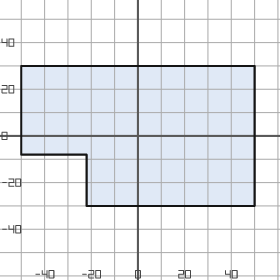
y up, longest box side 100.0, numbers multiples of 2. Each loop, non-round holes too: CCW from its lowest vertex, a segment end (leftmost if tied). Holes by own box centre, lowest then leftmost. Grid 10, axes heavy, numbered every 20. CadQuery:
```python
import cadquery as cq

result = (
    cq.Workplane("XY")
    .moveTo(-22.0, -30.0)
    .lineTo(50.0, -30.0)
    .lineTo(50.0, 30.0)
    .lineTo(-50.0, 30.0)
    .lineTo(-50.0, -8.0)
    .lineTo(-22.0, -8.0)
    .close()
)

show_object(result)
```